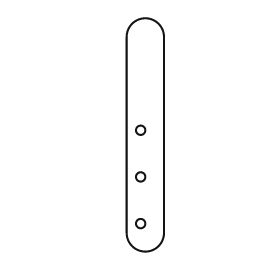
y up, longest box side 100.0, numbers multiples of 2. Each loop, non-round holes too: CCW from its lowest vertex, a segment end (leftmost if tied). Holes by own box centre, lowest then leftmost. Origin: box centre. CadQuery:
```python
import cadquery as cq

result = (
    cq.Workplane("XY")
    .moveTo(-8.0, -42.0)
    .threePointArc((0.0, -50.0), (8.0, -42.0))
    .lineTo(8.0, 42.0)
    .threePointArc((0.0, 50.0), (-8.0, 42.0))
    .close()
    .moveTo(-2.0, -38.0)
    .circle(2.0)
    .moveTo(-2.0, -18.0)
    .circle(2.0)
    .moveTo(-2.0, 2.0)
    .circle(2.0)
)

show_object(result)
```